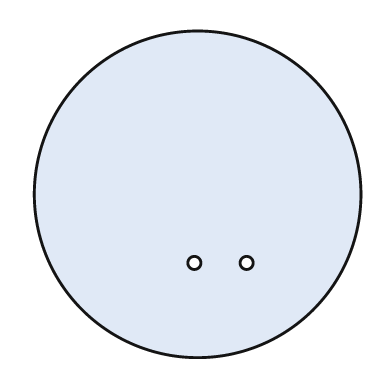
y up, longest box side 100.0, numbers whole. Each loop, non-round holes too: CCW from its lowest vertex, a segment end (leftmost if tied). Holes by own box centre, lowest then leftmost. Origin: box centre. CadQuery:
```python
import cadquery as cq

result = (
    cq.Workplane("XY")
    .moveTo(0.0, 0.0)
    .circle(50.0)
    .moveTo(-1.0, -21.0)
    .circle(2.0)
    .moveTo(15.0, -21.0)
    .circle(2.0)
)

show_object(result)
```